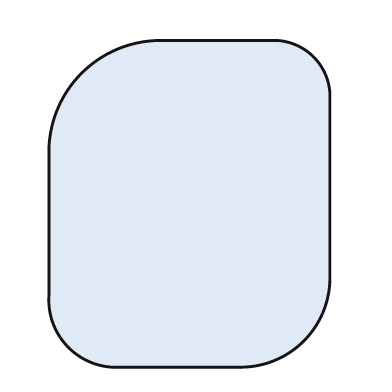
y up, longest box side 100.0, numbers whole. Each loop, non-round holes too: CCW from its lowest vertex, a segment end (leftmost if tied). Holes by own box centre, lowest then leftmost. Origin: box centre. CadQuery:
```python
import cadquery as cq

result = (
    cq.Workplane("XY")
    .moveTo(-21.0, -50.0)
    .lineTo(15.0, -50.0)
    .threePointArc((35.0, -42.0), (43.0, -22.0))
    .lineTo(43.0, 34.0)
    .threePointArc((38.0, 45.0), (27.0, 50.0))
    .lineTo(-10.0, 50.0)
    .threePointArc((-33.0, 40.0), (-43.0, 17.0))
    .lineTo(-43.0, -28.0)
    .threePointArc((-37.0, -44.0), (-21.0, -50.0))
    .close()
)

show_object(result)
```